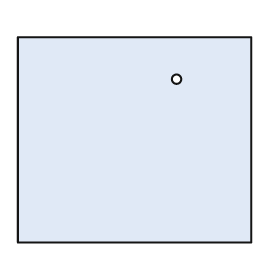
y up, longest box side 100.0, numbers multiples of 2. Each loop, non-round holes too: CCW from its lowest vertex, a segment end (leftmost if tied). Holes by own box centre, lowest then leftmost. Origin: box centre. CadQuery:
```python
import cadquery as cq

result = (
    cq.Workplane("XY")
    .moveTo(-50.0, -44.0)
    .lineTo(50.0, -44.0)
    .lineTo(50.0, 44.0)
    .lineTo(-50.0, 44.0)
    .close()
    .moveTo(18.0, 26.0)
    .circle(2.0)
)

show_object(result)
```